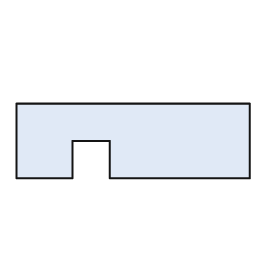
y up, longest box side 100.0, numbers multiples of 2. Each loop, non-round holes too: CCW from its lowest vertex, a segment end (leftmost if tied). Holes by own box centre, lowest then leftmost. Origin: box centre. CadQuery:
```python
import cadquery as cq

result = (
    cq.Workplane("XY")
    .moveTo(-50.0, -16.0)
    .lineTo(-26.0, -16.0)
    .lineTo(-26.0, 0.0)
    .lineTo(-10.0, 0.0)
    .lineTo(-10.0, -16.0)
    .lineTo(50.0, -16.0)
    .lineTo(50.0, 16.0)
    .lineTo(-50.0, 16.0)
    .close()
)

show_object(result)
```